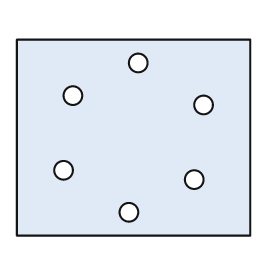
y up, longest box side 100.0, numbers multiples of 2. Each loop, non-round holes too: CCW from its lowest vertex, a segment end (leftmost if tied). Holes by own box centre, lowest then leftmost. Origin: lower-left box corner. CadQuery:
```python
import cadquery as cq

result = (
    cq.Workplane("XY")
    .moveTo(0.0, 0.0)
    .lineTo(100.0, 0.0)
    .lineTo(100.0, 84.0)
    .lineTo(0.0, 84.0)
    .close()
    .moveTo(48.0, 10.0)
    .circle(4.0)
    .moveTo(76.0, 24.0)
    .circle(4.0)
    .moveTo(20.0, 28.0)
    .circle(4.0)
    .moveTo(80.0, 56.0)
    .circle(4.0)
    .moveTo(24.0, 60.0)
    .circle(4.0)
    .moveTo(52.0, 74.0)
    .circle(4.0)
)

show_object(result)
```